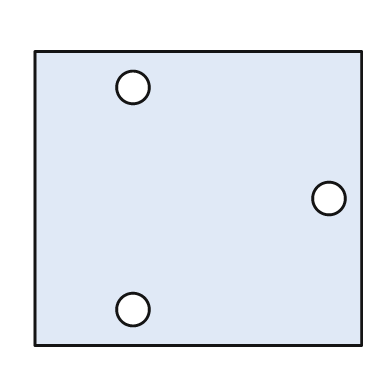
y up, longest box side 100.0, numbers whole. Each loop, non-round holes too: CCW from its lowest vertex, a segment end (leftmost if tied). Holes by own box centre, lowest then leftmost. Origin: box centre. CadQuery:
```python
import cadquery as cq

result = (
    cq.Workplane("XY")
    .moveTo(-50.0, -45.0)
    .lineTo(50.0, -45.0)
    .lineTo(50.0, 45.0)
    .lineTo(-50.0, 45.0)
    .close()
    .moveTo(-20.0, -34.0)
    .circle(5.0)
    .moveTo(40.0, 0.0)
    .circle(5.0)
    .moveTo(-20.0, 34.0)
    .circle(5.0)
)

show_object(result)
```